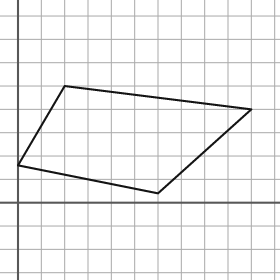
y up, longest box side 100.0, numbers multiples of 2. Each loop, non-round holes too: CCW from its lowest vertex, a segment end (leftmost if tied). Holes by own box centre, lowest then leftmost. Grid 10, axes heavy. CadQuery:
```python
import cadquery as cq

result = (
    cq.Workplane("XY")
    .moveTo(60.0, 4.0)
    .lineTo(100.0, 40.0)
    .lineTo(20.0, 50.0)
    .lineTo(0.0, 16.0)
    .close()
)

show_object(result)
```